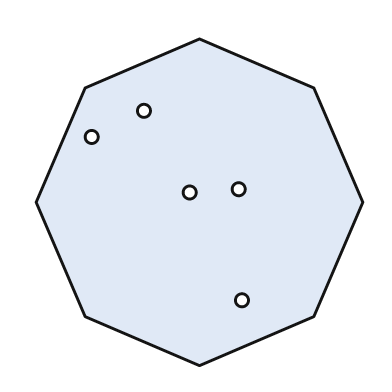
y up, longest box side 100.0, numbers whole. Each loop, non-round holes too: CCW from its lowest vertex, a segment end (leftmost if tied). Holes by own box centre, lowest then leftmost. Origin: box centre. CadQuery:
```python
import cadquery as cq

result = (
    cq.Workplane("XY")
    .moveTo(0.0, -50.0)
    .lineTo(35.0, -35.0)
    .lineTo(50.0, 0.0)
    .lineTo(35.0, 35.0)
    .lineTo(0.0, 50.0)
    .lineTo(-35.0, 35.0)
    .lineTo(-50.0, 0.0)
    .lineTo(-35.0, -35.0)
    .close()
    .moveTo(13.0, -30.0)
    .circle(2.0)
    .moveTo(-3.0, 3.0)
    .circle(2.0)
    .moveTo(12.0, 4.0)
    .circle(2.0)
    .moveTo(-33.0, 20.0)
    .circle(2.0)
    .moveTo(-17.0, 28.0)
    .circle(2.0)
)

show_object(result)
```